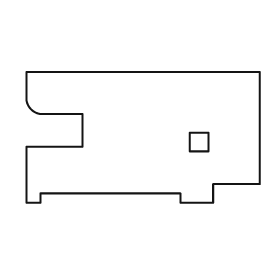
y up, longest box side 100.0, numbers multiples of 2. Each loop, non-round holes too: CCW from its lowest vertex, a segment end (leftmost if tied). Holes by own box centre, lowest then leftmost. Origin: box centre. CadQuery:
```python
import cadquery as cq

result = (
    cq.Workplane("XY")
    .moveTo(-50.0, -28.0)
    .lineTo(-44.0, -28.0)
    .lineTo(-44.0, -24.0)
    .lineTo(16.0, -24.0)
    .lineTo(16.0, -28.0)
    .lineTo(30.0, -28.0)
    .lineTo(30.0, -20.0)
    .lineTo(50.0, -20.0)
    .lineTo(50.0, 28.0)
    .lineTo(-50.0, 28.0)
    .lineTo(-50.0, 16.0)
    .threePointArc((-48.0, 12.0), (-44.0, 10.0))
    .lineTo(-26.0, 10.0)
    .lineTo(-26.0, -4.0)
    .lineTo(-50.0, -4.0)
    .close()
    .moveTo(20.0, -6.0)
    .lineTo(28.0, -6.0)
    .lineTo(28.0, 2.0)
    .lineTo(20.0, 2.0)
    .close()
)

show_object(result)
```